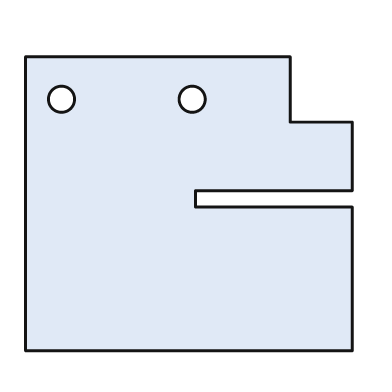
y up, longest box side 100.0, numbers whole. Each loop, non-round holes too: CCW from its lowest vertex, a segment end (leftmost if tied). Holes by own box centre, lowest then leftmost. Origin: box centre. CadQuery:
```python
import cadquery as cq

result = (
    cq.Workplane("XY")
    .moveTo(-50.0, -45.0)
    .lineTo(50.0, -45.0)
    .lineTo(50.0, -1.0)
    .lineTo(2.0, -1.0)
    .lineTo(2.0, 4.0)
    .lineTo(50.0, 4.0)
    .lineTo(50.0, 25.0)
    .lineTo(31.0, 25.0)
    .lineTo(31.0, 45.0)
    .lineTo(-50.0, 45.0)
    .close()
    .moveTo(-39.0, 32.0)
    .circle(4.0)
    .moveTo(1.0, 32.0)
    .circle(4.0)
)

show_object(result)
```